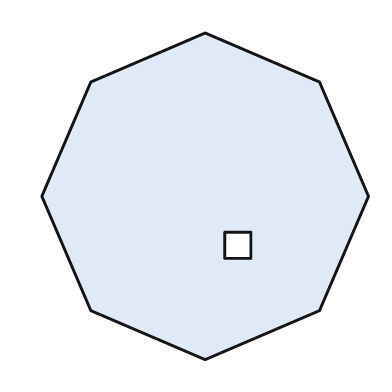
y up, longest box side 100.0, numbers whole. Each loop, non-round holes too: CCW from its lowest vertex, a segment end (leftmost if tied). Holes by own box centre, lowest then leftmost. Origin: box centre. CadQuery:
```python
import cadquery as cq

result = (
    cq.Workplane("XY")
    .moveTo(0.0, -50.0)
    .lineTo(35.0, -35.0)
    .lineTo(50.0, 0.0)
    .lineTo(35.0, 35.0)
    .lineTo(0.0, 50.0)
    .lineTo(-35.0, 35.0)
    .lineTo(-50.0, 0.0)
    .lineTo(-35.0, -35.0)
    .close()
    .moveTo(6.0, -19.0)
    .lineTo(14.0, -19.0)
    .lineTo(14.0, -11.0)
    .lineTo(6.0, -11.0)
    .close()
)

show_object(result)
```